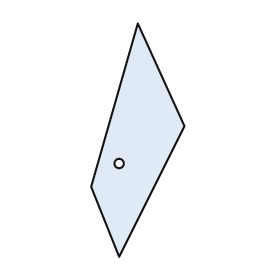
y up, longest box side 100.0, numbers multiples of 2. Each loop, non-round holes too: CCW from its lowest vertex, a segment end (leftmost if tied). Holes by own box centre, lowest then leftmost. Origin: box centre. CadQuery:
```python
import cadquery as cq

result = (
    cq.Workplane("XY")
    .moveTo(-8.0, -50.0)
    .lineTo(20.0, 6.0)
    .lineTo(0.0, 50.0)
    .lineTo(-20.0, -20.0)
    .close()
    .moveTo(-8.0, -10.0)
    .circle(2.0)
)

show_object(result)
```